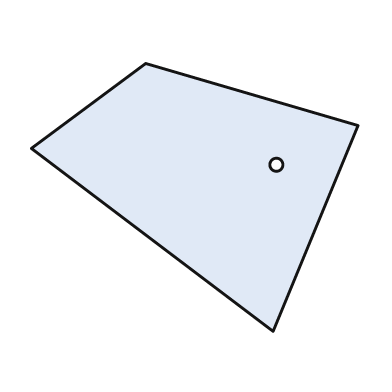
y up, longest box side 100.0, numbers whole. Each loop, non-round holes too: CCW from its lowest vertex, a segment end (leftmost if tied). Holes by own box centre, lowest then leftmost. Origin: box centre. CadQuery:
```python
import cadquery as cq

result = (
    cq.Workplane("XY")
    .moveTo(24.0, -41.0)
    .lineTo(50.0, 22.0)
    .lineTo(-15.0, 41.0)
    .lineTo(-50.0, 15.0)
    .close()
    .moveTo(25.0, 10.0)
    .circle(2.0)
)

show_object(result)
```